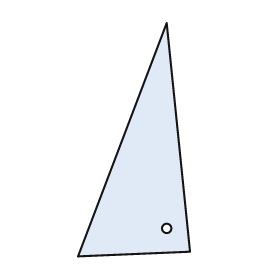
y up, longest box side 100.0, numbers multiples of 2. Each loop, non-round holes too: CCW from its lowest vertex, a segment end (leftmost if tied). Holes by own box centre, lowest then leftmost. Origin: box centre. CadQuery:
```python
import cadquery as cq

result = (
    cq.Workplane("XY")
    .moveTo(-24.0, -50.0)
    .lineTo(24.0, -48.0)
    .lineTo(14.0, 50.0)
    .close()
    .moveTo(14.0, -38.0)
    .circle(2.0)
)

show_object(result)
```